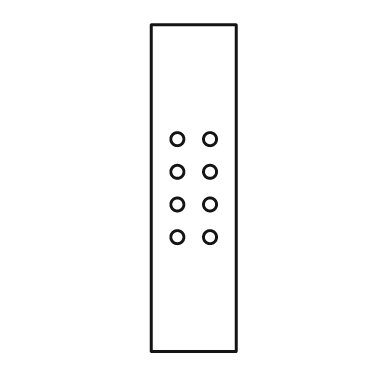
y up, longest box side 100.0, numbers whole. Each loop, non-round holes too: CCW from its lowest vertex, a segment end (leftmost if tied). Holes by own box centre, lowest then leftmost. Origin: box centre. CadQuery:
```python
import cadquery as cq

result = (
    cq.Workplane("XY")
    .moveTo(-13.0, -50.0)
    .lineTo(13.0, -50.0)
    .lineTo(13.0, 50.0)
    .lineTo(-13.0, 50.0)
    .close()
    .moveTo(-5.0, -15.0)
    .circle(2.0)
    .moveTo(5.0, -15.0)
    .circle(2.0)
    .moveTo(-5.0, -5.0)
    .circle(2.0)
    .moveTo(5.0, -5.0)
    .circle(2.0)
    .moveTo(-5.0, 5.0)
    .circle(2.0)
    .moveTo(5.0, 5.0)
    .circle(2.0)
    .moveTo(-5.0, 15.0)
    .circle(2.0)
    .moveTo(5.0, 15.0)
    .circle(2.0)
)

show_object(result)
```